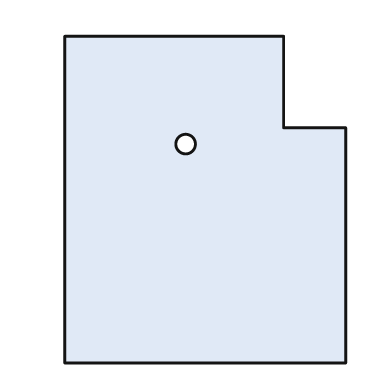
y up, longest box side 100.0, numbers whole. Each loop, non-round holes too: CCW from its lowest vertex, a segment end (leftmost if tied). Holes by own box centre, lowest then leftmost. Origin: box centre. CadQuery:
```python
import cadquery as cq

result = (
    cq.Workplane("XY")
    .moveTo(-43.0, -50.0)
    .lineTo(43.0, -50.0)
    .lineTo(43.0, 22.0)
    .lineTo(24.0, 22.0)
    .lineTo(24.0, 50.0)
    .lineTo(-43.0, 50.0)
    .close()
    .moveTo(-6.0, 17.0)
    .circle(3.0)
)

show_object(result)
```